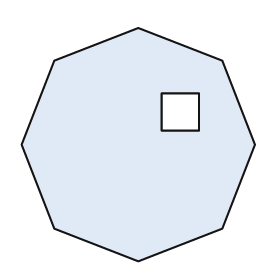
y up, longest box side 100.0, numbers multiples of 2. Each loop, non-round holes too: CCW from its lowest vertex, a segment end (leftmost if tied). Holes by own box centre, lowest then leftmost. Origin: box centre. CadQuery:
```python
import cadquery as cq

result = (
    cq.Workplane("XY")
    .moveTo(0.0, -50.0)
    .lineTo(36.0, -36.0)
    .lineTo(50.0, 0.0)
    .lineTo(36.0, 36.0)
    .lineTo(0.0, 50.0)
    .lineTo(-36.0, 36.0)
    .lineTo(-50.0, 0.0)
    .lineTo(-36.0, -36.0)
    .close()
    .moveTo(10.0, 6.0)
    .lineTo(26.0, 6.0)
    .lineTo(26.0, 22.0)
    .lineTo(10.0, 22.0)
    .close()
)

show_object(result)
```